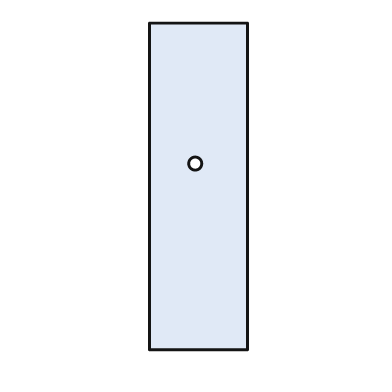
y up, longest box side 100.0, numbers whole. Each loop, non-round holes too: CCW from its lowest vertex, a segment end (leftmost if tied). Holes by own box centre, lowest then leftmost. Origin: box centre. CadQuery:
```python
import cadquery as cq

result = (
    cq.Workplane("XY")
    .moveTo(-15.0, -50.0)
    .lineTo(15.0, -50.0)
    .lineTo(15.0, 50.0)
    .lineTo(-15.0, 50.0)
    .close()
    .moveTo(-1.0, 7.0)
    .circle(2.0)
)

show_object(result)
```